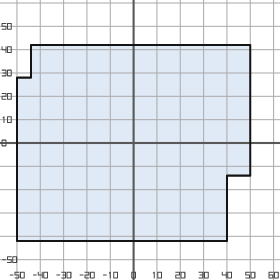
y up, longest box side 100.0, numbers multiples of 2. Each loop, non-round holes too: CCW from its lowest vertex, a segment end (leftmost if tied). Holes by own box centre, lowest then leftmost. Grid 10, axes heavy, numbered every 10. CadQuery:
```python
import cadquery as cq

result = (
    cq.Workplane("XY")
    .moveTo(-50.0, -42.0)
    .lineTo(40.0, -42.0)
    .lineTo(40.0, -14.0)
    .lineTo(50.0, -14.0)
    .lineTo(50.0, 42.0)
    .lineTo(-44.0, 42.0)
    .lineTo(-44.0, 28.0)
    .lineTo(-50.0, 28.0)
    .close()
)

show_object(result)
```